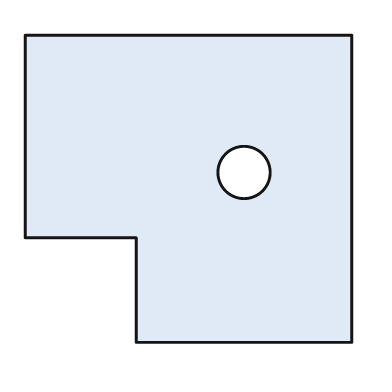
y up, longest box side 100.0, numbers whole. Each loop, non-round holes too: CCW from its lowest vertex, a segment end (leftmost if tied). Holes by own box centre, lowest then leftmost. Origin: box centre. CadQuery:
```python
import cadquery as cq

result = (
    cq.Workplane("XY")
    .moveTo(-16.0, -47.0)
    .lineTo(50.0, -47.0)
    .lineTo(50.0, 47.0)
    .lineTo(-50.0, 47.0)
    .lineTo(-50.0, -15.0)
    .lineTo(-16.0, -15.0)
    .close()
    .moveTo(17.0, 5.0)
    .circle(8.0)
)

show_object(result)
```